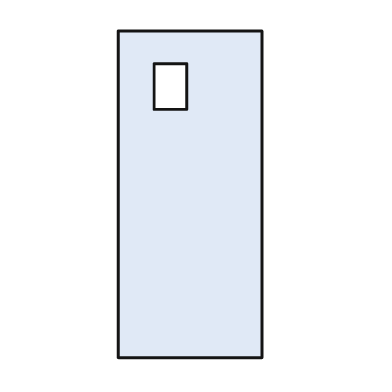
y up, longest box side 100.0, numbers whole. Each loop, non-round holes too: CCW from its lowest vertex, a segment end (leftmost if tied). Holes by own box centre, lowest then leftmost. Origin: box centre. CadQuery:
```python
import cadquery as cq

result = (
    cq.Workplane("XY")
    .moveTo(-22.0, -50.0)
    .lineTo(22.0, -50.0)
    .lineTo(22.0, 50.0)
    .lineTo(-22.0, 50.0)
    .close()
    .moveTo(-11.0, 26.0)
    .lineTo(-1.0, 26.0)
    .lineTo(-1.0, 40.0)
    .lineTo(-11.0, 40.0)
    .close()
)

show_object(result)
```